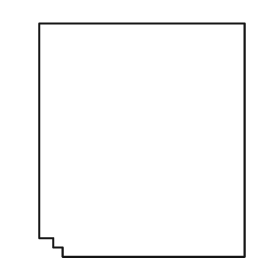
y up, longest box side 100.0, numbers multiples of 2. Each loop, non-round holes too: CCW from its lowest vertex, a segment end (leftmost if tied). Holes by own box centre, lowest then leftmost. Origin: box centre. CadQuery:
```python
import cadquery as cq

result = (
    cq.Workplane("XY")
    .moveTo(-34.0, -50.0)
    .lineTo(44.0, -50.0)
    .lineTo(44.0, 50.0)
    .lineTo(-44.0, 50.0)
    .lineTo(-44.0, -42.0)
    .lineTo(-38.0, -42.0)
    .lineTo(-38.0, -46.0)
    .lineTo(-34.0, -46.0)
    .close()
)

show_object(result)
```